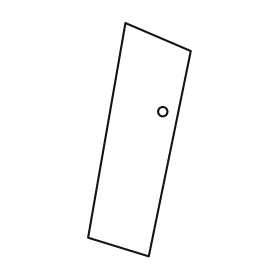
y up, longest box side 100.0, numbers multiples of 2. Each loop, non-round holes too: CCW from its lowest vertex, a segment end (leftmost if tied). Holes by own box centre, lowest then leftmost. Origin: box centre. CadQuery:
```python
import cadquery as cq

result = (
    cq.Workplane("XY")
    .moveTo(4.0, -50.0)
    .lineTo(22.0, 38.0)
    .lineTo(-6.0, 50.0)
    .lineTo(-22.0, -42.0)
    .close()
    .moveTo(10.0, 12.0)
    .circle(2.0)
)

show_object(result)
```